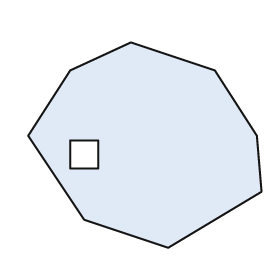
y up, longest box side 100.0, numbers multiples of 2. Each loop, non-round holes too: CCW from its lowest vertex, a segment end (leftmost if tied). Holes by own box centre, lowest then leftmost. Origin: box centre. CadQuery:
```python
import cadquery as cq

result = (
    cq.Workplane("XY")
    .moveTo(10.0, -44.0)
    .lineTo(50.0, -20.0)
    .lineTo(48.0, 4.0)
    .lineTo(30.0, 32.0)
    .lineTo(-6.0, 44.0)
    .lineTo(-32.0, 32.0)
    .lineTo(-50.0, 4.0)
    .lineTo(-26.0, -32.0)
    .close()
    .moveTo(-32.0, -10.0)
    .lineTo(-20.0, -10.0)
    .lineTo(-20.0, 2.0)
    .lineTo(-32.0, 2.0)
    .close()
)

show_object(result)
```